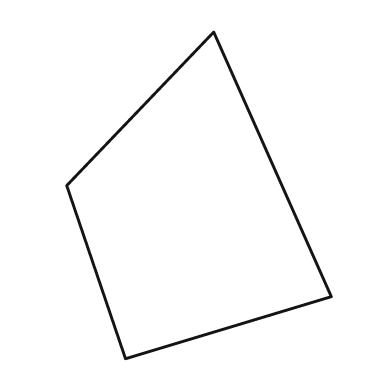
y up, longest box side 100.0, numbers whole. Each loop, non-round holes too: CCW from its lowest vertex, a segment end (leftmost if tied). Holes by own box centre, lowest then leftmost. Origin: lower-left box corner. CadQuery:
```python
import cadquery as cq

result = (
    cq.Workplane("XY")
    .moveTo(18.0, 0.0)
    .lineTo(81.0, 19.0)
    .lineTo(45.0, 100.0)
    .lineTo(0.0, 53.0)
    .close()
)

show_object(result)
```